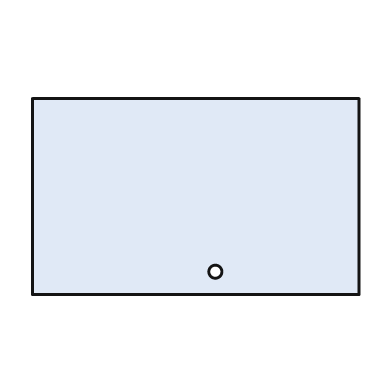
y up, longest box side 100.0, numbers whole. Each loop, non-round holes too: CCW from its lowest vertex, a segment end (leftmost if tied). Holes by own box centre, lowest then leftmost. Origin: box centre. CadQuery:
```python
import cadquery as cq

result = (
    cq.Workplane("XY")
    .moveTo(-50.0, -30.0)
    .lineTo(50.0, -30.0)
    .lineTo(50.0, 30.0)
    .lineTo(-50.0, 30.0)
    .close()
    .moveTo(6.0, -23.0)
    .circle(2.0)
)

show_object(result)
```